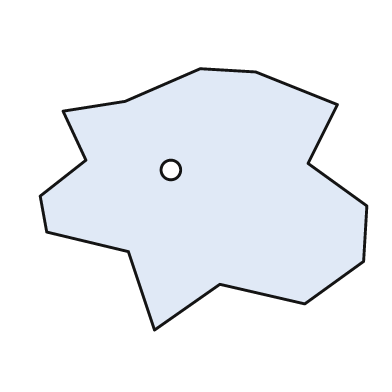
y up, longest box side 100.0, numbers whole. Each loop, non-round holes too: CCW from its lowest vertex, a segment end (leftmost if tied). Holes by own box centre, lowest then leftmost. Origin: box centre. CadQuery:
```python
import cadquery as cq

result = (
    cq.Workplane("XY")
    .moveTo(-15.0, -40.0)
    .lineTo(5.0, -26.0)
    .lineTo(31.0, -32.0)
    .lineTo(49.0, -19.0)
    .lineTo(50.0, -2.0)
    .lineTo(32.0, 11.0)
    .lineTo(41.0, 29.0)
    .lineTo(16.0, 39.0)
    .lineTo(-1.0, 40.0)
    .lineTo(-24.0, 30.0)
    .lineTo(-43.0, 27.0)
    .lineTo(-36.0, 12.0)
    .lineTo(-50.0, 1.0)
    .lineTo(-48.0, -10.0)
    .lineTo(-23.0, -16.0)
    .close()
    .moveTo(-10.0, 9.0)
    .circle(3.0)
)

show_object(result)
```